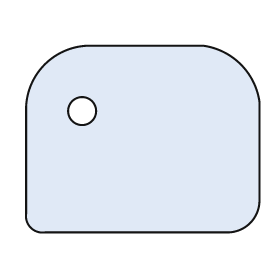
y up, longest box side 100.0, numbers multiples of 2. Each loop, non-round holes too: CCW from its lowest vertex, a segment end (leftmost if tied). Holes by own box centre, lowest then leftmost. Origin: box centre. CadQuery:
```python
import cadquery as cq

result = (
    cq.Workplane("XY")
    .moveTo(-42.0, -40.0)
    .lineTo(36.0, -40.0)
    .threePointArc((46.0, -36.0), (50.0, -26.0))
    .lineTo(50.0, 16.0)
    .threePointArc((42.0, 32.0), (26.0, 40.0))
    .lineTo(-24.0, 40.0)
    .threePointArc((-42.0, 32.0), (-50.0, 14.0))
    .lineTo(-50.0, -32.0)
    .threePointArc((-48.0, -38.0), (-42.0, -40.0))
    .close()
    .moveTo(-26.0, 12.0)
    .circle(6.0)
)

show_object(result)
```